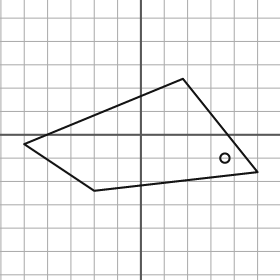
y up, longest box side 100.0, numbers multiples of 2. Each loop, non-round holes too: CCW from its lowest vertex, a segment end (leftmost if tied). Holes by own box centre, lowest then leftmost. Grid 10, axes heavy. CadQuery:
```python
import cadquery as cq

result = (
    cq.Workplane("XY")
    .moveTo(-20.0, -24.0)
    .lineTo(50.0, -16.0)
    .lineTo(18.0, 24.0)
    .lineTo(-50.0, -4.0)
    .close()
    .moveTo(36.0, -10.0)
    .circle(2.0)
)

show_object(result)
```